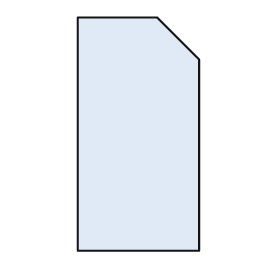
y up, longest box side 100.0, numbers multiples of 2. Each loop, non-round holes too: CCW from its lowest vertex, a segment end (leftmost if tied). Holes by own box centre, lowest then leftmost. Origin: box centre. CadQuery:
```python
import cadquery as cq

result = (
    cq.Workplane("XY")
    .moveTo(-26.0, -50.0)
    .lineTo(26.0, -50.0)
    .lineTo(26.0, 32.0)
    .lineTo(8.0, 50.0)
    .lineTo(-26.0, 50.0)
    .close()
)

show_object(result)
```